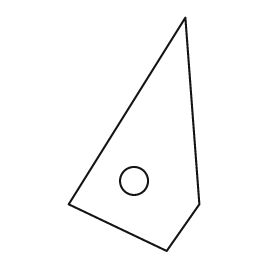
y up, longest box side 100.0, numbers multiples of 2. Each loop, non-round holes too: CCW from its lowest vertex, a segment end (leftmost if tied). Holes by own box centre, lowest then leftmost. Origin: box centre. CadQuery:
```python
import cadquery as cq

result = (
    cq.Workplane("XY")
    .moveTo(14.0, -50.0)
    .lineTo(28.0, -30.0)
    .lineTo(22.0, 50.0)
    .lineTo(-28.0, -30.0)
    .close()
    .moveTo(0.0, -20.0)
    .circle(6.0)
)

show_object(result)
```